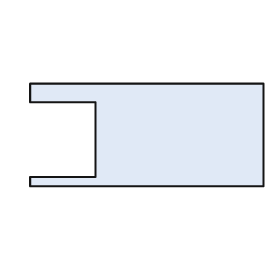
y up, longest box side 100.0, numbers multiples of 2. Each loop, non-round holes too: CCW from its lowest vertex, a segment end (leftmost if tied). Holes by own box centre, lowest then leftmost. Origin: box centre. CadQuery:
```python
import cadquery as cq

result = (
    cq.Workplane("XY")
    .moveTo(-50.0, -22.0)
    .lineTo(50.0, -22.0)
    .lineTo(50.0, 22.0)
    .lineTo(-50.0, 22.0)
    .lineTo(-50.0, 14.0)
    .lineTo(-22.0, 14.0)
    .lineTo(-22.0, -18.0)
    .lineTo(-50.0, -18.0)
    .close()
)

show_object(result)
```